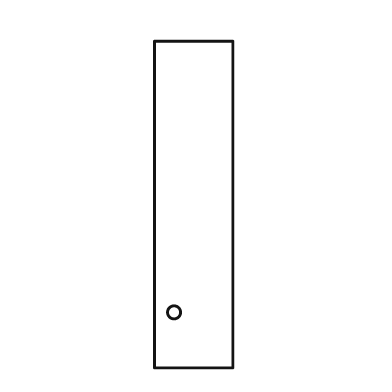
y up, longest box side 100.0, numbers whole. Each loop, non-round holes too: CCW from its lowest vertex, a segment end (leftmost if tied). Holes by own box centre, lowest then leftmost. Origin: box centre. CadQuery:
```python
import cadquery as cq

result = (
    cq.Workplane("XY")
    .moveTo(-12.0, -50.0)
    .lineTo(12.0, -50.0)
    .lineTo(12.0, 50.0)
    .lineTo(-12.0, 50.0)
    .close()
    .moveTo(-6.0, -33.0)
    .circle(2.0)
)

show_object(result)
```